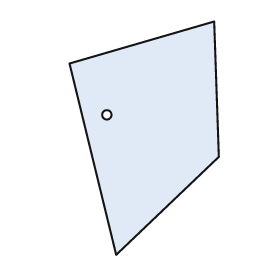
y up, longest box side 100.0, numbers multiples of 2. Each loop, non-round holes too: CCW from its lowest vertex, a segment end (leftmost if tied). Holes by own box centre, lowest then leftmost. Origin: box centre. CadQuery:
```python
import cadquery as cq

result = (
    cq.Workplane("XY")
    .moveTo(-12.0, -50.0)
    .lineTo(32.0, -8.0)
    .lineTo(30.0, 50.0)
    .lineTo(-32.0, 32.0)
    .close()
    .moveTo(-16.0, 10.0)
    .circle(2.0)
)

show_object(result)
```